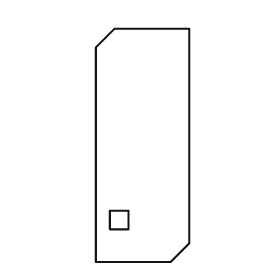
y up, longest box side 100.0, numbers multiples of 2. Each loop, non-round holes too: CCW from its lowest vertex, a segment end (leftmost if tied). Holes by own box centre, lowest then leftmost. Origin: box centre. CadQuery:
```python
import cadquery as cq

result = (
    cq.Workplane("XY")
    .moveTo(-20.0, -50.0)
    .lineTo(12.0, -50.0)
    .lineTo(20.0, -42.0)
    .lineTo(20.0, 50.0)
    .lineTo(-12.0, 50.0)
    .lineTo(-20.0, 42.0)
    .close()
    .moveTo(-14.0, -36.0)
    .lineTo(-6.0, -36.0)
    .lineTo(-6.0, -28.0)
    .lineTo(-14.0, -28.0)
    .close()
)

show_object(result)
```